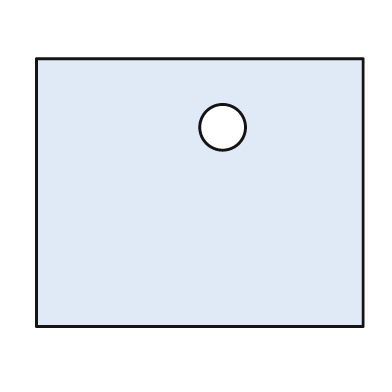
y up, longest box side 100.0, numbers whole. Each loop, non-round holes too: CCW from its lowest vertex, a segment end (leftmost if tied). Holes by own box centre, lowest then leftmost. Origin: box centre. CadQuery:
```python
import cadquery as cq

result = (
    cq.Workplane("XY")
    .moveTo(-50.0, -41.0)
    .lineTo(50.0, -41.0)
    .lineTo(50.0, 41.0)
    .lineTo(-50.0, 41.0)
    .close()
    .moveTo(7.0, 20.0)
    .circle(7.0)
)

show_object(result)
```